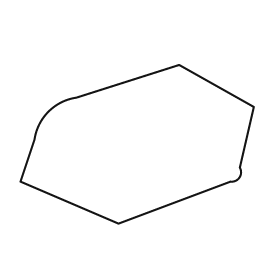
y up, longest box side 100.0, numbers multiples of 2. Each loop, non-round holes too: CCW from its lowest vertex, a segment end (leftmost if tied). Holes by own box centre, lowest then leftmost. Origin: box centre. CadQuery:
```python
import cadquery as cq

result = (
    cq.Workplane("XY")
    .moveTo(-8.0, -34.0)
    .lineTo(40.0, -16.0)
    .threePointArc((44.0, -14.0), (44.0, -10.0))
    .lineTo(50.0, 16.0)
    .lineTo(18.0, 34.0)
    .lineTo(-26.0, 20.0)
    .threePointArc((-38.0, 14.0), (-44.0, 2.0))
    .lineTo(-50.0, -16.0)
    .close()
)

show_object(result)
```